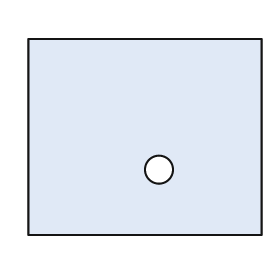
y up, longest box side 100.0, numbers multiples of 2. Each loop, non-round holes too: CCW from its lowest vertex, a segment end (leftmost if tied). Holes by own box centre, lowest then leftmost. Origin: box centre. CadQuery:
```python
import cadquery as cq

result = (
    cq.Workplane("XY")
    .moveTo(-50.0, -42.0)
    .lineTo(50.0, -42.0)
    .lineTo(50.0, 42.0)
    .lineTo(-50.0, 42.0)
    .close()
    .moveTo(6.0, -14.0)
    .circle(6.0)
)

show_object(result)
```